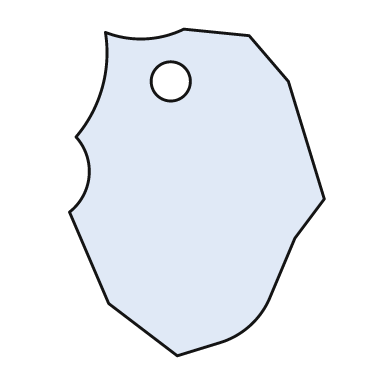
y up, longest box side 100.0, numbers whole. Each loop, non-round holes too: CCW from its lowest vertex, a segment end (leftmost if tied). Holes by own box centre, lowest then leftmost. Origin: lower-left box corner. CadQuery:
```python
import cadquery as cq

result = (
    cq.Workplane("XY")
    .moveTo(33.0, 0.0)
    .lineTo(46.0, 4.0)
    .threePointArc((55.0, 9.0), (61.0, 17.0))
    .lineTo(69.0, 36.0)
    .lineTo(78.0, 48.0)
    .lineTo(67.0, 84.0)
    .lineTo(55.0, 98.0)
    .lineTo(35.0, 100.0)
    .threePointArc((23.0, 97.0), (11.0, 99.0))
    .threePointArc((10.0, 82.0), (2.0, 67.0))
    .threePointArc((6.0, 55.0), (0.0, 44.0))
    .lineTo(12.0, 16.0)
    .close()
    .moveTo(31.0, 84.0)
    .circle(6.0)
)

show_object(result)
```